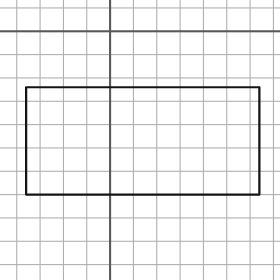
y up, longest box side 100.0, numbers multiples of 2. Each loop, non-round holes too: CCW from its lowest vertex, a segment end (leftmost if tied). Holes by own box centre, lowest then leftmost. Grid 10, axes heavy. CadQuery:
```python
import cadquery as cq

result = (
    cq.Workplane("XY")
    .moveTo(-36.0, -70.0)
    .lineTo(64.0, -70.0)
    .lineTo(64.0, -24.0)
    .lineTo(-36.0, -24.0)
    .close()
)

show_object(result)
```